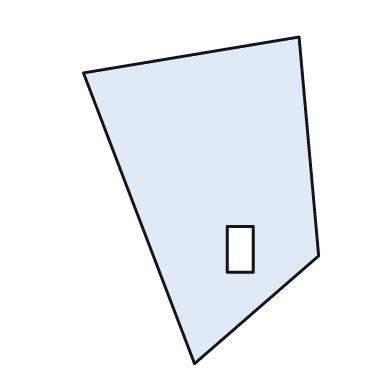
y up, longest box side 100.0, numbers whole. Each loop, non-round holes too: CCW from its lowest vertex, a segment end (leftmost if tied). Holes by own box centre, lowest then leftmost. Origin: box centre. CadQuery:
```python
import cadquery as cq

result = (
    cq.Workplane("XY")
    .moveTo(-2.0, -50.0)
    .lineTo(36.0, -17.0)
    .lineTo(30.0, 50.0)
    .lineTo(-36.0, 39.0)
    .close()
    .moveTo(8.0, -22.0)
    .lineTo(16.0, -22.0)
    .lineTo(16.0, -8.0)
    .lineTo(8.0, -8.0)
    .close()
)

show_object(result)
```